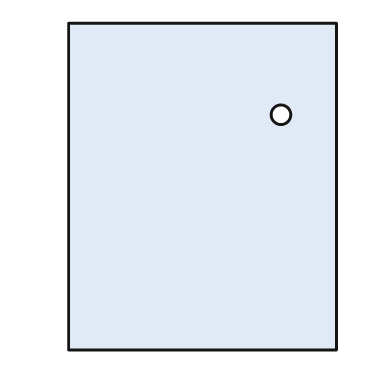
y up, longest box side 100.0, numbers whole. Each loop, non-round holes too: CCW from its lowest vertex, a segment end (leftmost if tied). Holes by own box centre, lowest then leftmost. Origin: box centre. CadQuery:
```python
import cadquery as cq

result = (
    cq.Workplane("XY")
    .moveTo(-41.0, -50.0)
    .lineTo(41.0, -50.0)
    .lineTo(41.0, 50.0)
    .lineTo(-41.0, 50.0)
    .close()
    .moveTo(24.0, 22.0)
    .circle(3.0)
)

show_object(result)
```